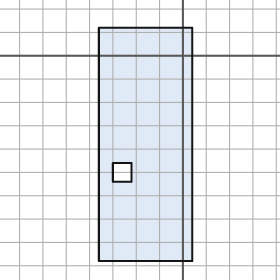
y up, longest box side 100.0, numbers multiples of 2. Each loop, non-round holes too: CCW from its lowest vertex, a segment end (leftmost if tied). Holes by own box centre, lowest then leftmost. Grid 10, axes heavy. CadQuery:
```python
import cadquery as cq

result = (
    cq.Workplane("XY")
    .moveTo(-36.0, -88.0)
    .lineTo(4.0, -88.0)
    .lineTo(4.0, 12.0)
    .lineTo(-36.0, 12.0)
    .close()
    .moveTo(-30.0, -54.0)
    .lineTo(-22.0, -54.0)
    .lineTo(-22.0, -46.0)
    .lineTo(-30.0, -46.0)
    .close()
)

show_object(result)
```